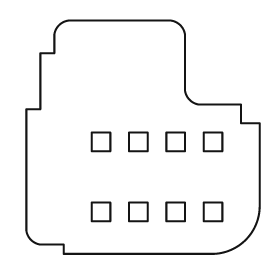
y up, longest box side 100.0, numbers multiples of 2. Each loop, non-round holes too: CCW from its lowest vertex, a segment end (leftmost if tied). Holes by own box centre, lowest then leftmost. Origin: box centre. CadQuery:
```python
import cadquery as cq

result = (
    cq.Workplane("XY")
    .moveTo(-34.0, -50.0)
    .lineTo(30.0, -50.0)
    .threePointArc((44.0, -44.0), (50.0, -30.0))
    .lineTo(50.0, 6.0)
    .lineTo(42.0, 6.0)
    .lineTo(42.0, 14.0)
    .lineTo(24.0, 14.0)
    .threePointArc((20.0, 16.0), (18.0, 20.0))
    .lineTo(18.0, 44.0)
    .threePointArc((16.0, 48.0), (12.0, 50.0))
    .lineTo(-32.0, 50.0)
    .threePointArc((-36.0, 48.0), (-38.0, 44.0))
    .lineTo(-38.0, 36.0)
    .lineTo(-44.0, 36.0)
    .lineTo(-44.0, 12.0)
    .lineTo(-50.0, 12.0)
    .lineTo(-50.0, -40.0)
    .threePointArc((-48.0, -44.0), (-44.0, -46.0))
    .lineTo(-34.0, -46.0)
    .close()
    .moveTo(-22.0, -36.0)
    .lineTo(-14.0, -36.0)
    .lineTo(-14.0, -28.0)
    .lineTo(-22.0, -28.0)
    .close()
    .moveTo(-6.0, -36.0)
    .lineTo(2.0, -36.0)
    .lineTo(2.0, -28.0)
    .lineTo(-6.0, -28.0)
    .close()
    .moveTo(10.0, -36.0)
    .lineTo(18.0, -36.0)
    .lineTo(18.0, -28.0)
    .lineTo(10.0, -28.0)
    .close()
    .moveTo(26.0, -36.0)
    .lineTo(34.0, -36.0)
    .lineTo(34.0, -28.0)
    .lineTo(26.0, -28.0)
    .close()
    .moveTo(-22.0, -6.0)
    .lineTo(-14.0, -6.0)
    .lineTo(-14.0, 2.0)
    .lineTo(-22.0, 2.0)
    .close()
    .moveTo(-6.0, -6.0)
    .lineTo(2.0, -6.0)
    .lineTo(2.0, 2.0)
    .lineTo(-6.0, 2.0)
    .close()
    .moveTo(10.0, -6.0)
    .lineTo(18.0, -6.0)
    .lineTo(18.0, 2.0)
    .lineTo(10.0, 2.0)
    .close()
    .moveTo(26.0, -6.0)
    .lineTo(34.0, -6.0)
    .lineTo(34.0, 2.0)
    .lineTo(26.0, 2.0)
    .close()
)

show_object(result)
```